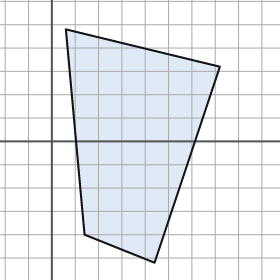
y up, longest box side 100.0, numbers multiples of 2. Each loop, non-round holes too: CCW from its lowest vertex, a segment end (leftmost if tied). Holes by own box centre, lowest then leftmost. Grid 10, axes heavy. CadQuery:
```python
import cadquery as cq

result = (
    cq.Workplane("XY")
    .moveTo(44.0, -52.0)
    .lineTo(72.0, 32.0)
    .lineTo(6.0, 48.0)
    .lineTo(14.0, -40.0)
    .close()
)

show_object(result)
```